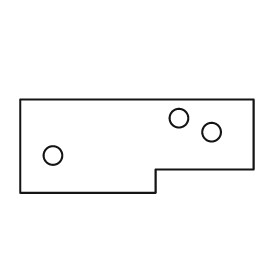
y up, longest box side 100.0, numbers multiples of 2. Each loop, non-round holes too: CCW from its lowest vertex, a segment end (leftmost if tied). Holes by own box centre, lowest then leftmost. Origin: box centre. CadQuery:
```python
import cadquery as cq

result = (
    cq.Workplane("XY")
    .moveTo(-50.0, -20.0)
    .lineTo(8.0, -20.0)
    .lineTo(8.0, -10.0)
    .lineTo(50.0, -10.0)
    .lineTo(50.0, 20.0)
    .lineTo(-50.0, 20.0)
    .close()
    .moveTo(-36.0, -4.0)
    .circle(4.0)
    .moveTo(32.0, 6.0)
    .circle(4.0)
    .moveTo(18.0, 12.0)
    .circle(4.0)
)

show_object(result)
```